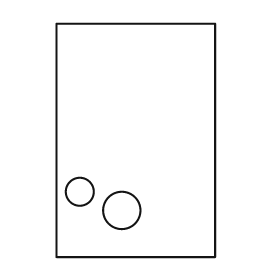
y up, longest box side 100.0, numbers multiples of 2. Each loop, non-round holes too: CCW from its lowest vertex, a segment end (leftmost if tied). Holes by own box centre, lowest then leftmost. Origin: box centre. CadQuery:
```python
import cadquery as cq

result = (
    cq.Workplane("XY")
    .moveTo(-34.0, -50.0)
    .lineTo(34.0, -50.0)
    .lineTo(34.0, 50.0)
    .lineTo(-34.0, 50.0)
    .close()
    .moveTo(-6.0, -30.0)
    .circle(8.0)
    .moveTo(-24.0, -22.0)
    .circle(6.0)
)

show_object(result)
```